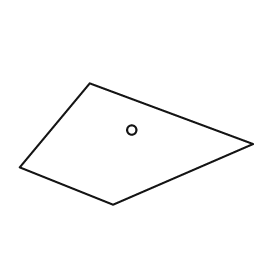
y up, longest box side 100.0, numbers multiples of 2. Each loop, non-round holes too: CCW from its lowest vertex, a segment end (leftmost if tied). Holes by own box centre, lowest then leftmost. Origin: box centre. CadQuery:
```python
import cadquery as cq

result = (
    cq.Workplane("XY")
    .moveTo(-10.0, -26.0)
    .lineTo(50.0, 0.0)
    .lineTo(-20.0, 26.0)
    .lineTo(-50.0, -10.0)
    .close()
    .moveTo(-2.0, 6.0)
    .circle(2.0)
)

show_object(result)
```